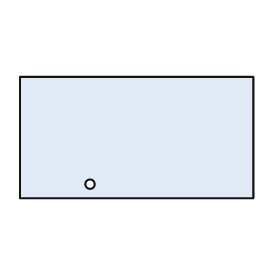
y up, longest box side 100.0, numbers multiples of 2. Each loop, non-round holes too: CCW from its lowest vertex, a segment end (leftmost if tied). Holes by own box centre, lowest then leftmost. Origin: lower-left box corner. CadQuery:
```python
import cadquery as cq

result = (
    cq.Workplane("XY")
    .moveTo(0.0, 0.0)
    .lineTo(100.0, 0.0)
    .lineTo(100.0, 52.0)
    .lineTo(0.0, 52.0)
    .close()
    .moveTo(30.0, 6.0)
    .circle(2.0)
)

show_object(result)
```